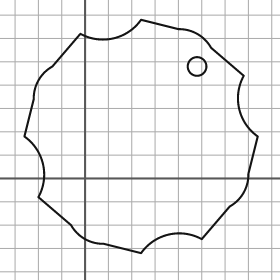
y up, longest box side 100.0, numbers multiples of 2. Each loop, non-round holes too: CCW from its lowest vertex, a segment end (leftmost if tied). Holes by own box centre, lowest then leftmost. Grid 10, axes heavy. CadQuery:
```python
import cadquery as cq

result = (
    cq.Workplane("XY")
    .moveTo(24.0, -32.0)
    .threePointArc((36.0, -24.0), (50.0, -26.0))
    .lineTo(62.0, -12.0)
    .threePointArc((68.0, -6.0), (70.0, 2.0))
    .lineTo(74.0, 18.0)
    .threePointArc((66.0, 30.0), (68.0, 44.0))
    .lineTo(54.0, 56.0)
    .threePointArc((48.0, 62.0), (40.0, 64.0))
    .lineTo(24.0, 68.0)
    .threePointArc((12.0, 60.0), (-2.0, 62.0))
    .lineTo(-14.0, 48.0)
    .threePointArc((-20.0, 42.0), (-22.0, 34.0))
    .lineTo(-26.0, 18.0)
    .threePointArc((-18.0, 6.0), (-20.0, -8.0))
    .lineTo(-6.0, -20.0)
    .threePointArc((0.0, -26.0), (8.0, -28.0))
    .close()
    .moveTo(48.0, 48.0)
    .circle(4.0)
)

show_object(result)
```